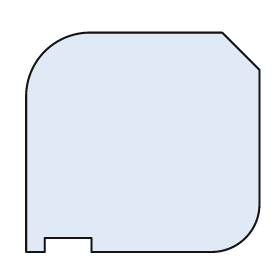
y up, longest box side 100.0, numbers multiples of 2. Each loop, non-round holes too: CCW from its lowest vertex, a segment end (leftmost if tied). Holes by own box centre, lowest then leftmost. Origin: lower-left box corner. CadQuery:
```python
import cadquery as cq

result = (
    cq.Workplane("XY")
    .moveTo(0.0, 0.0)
    .lineTo(8.0, 0.0)
    .lineTo(8.0, 6.0)
    .lineTo(28.0, 6.0)
    .lineTo(28.0, 0.0)
    .lineTo(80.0, 0.0)
    .threePointArc((94.0, 6.0), (100.0, 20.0))
    .lineTo(100.0, 78.0)
    .lineTo(84.0, 94.0)
    .lineTo(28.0, 94.0)
    .threePointArc((8.0, 86.0), (0.0, 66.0))
    .close()
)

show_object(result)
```